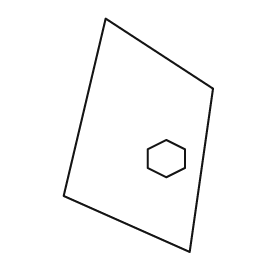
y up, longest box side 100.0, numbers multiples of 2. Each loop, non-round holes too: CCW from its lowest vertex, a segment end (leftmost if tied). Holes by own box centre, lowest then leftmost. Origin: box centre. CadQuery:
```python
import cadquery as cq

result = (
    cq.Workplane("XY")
    .moveTo(22.0, -50.0)
    .lineTo(32.0, 20.0)
    .lineTo(-14.0, 50.0)
    .lineTo(-32.0, -26.0)
    .close()
    .moveTo(12.0, -18.0)
    .lineTo(20.0, -14.0)
    .lineTo(20.0, -6.0)
    .lineTo(12.0, -2.0)
    .lineTo(4.0, -6.0)
    .lineTo(4.0, -14.0)
    .close()
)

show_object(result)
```